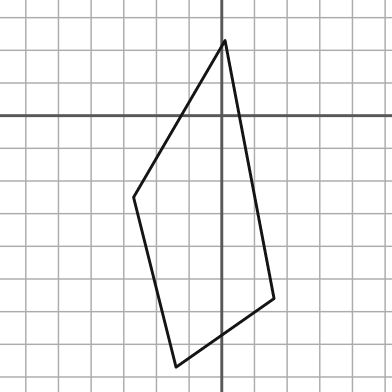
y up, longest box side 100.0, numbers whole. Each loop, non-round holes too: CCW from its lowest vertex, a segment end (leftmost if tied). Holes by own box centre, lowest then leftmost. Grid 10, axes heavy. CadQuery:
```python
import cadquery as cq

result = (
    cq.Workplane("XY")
    .moveTo(-14.0, -77.0)
    .lineTo(16.0, -56.0)
    .lineTo(1.0, 23.0)
    .lineTo(-27.0, -25.0)
    .close()
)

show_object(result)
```